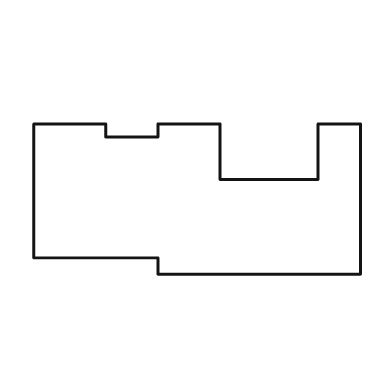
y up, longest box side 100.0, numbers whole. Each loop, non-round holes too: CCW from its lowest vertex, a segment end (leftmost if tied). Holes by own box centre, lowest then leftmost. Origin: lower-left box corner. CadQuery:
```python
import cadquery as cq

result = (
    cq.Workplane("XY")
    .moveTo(38.0, 0.0)
    .lineTo(100.0, 0.0)
    .lineTo(100.0, 46.0)
    .lineTo(87.0, 46.0)
    .lineTo(87.0, 29.0)
    .lineTo(57.0, 29.0)
    .lineTo(57.0, 46.0)
    .lineTo(38.0, 46.0)
    .lineTo(38.0, 42.0)
    .lineTo(22.0, 42.0)
    .lineTo(22.0, 46.0)
    .lineTo(0.0, 46.0)
    .lineTo(0.0, 5.0)
    .lineTo(38.0, 5.0)
    .close()
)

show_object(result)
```